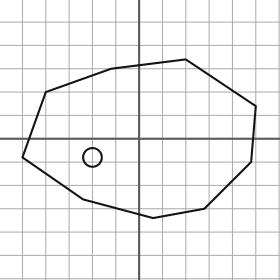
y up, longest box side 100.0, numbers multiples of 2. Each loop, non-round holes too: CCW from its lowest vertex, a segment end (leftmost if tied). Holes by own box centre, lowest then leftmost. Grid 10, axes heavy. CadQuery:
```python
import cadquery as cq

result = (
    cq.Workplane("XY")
    .moveTo(6.0, -34.0)
    .lineTo(28.0, -30.0)
    .lineTo(48.0, -10.0)
    .lineTo(50.0, 14.0)
    .lineTo(20.0, 34.0)
    .lineTo(-12.0, 30.0)
    .lineTo(-40.0, 20.0)
    .lineTo(-50.0, -8.0)
    .lineTo(-24.0, -26.0)
    .close()
    .moveTo(-20.0, -8.0)
    .circle(4.0)
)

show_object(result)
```